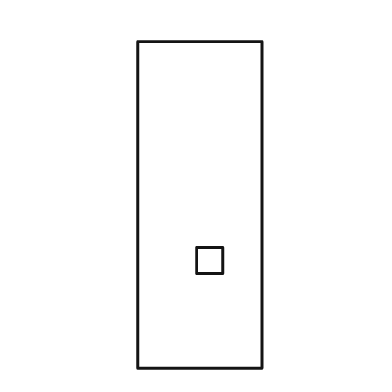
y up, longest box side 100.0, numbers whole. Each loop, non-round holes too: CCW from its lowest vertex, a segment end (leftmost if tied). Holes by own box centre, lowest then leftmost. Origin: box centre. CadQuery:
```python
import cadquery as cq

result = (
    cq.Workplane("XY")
    .moveTo(-19.0, -50.0)
    .lineTo(19.0, -50.0)
    .lineTo(19.0, 50.0)
    .lineTo(-19.0, 50.0)
    .close()
    .moveTo(-1.0, -21.0)
    .lineTo(7.0, -21.0)
    .lineTo(7.0, -13.0)
    .lineTo(-1.0, -13.0)
    .close()
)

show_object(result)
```